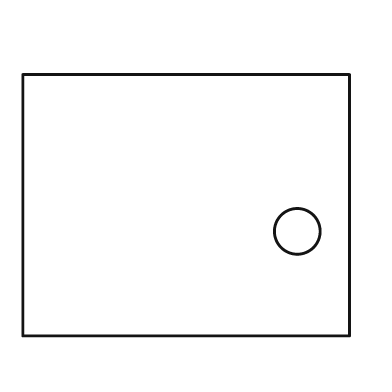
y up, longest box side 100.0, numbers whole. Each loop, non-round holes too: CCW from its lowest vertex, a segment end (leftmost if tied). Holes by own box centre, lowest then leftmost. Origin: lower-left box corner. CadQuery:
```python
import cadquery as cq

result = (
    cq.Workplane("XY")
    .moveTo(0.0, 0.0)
    .lineTo(100.0, 0.0)
    .lineTo(100.0, 80.0)
    .lineTo(0.0, 80.0)
    .close()
    .moveTo(84.0, 32.0)
    .circle(7.0)
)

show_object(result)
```